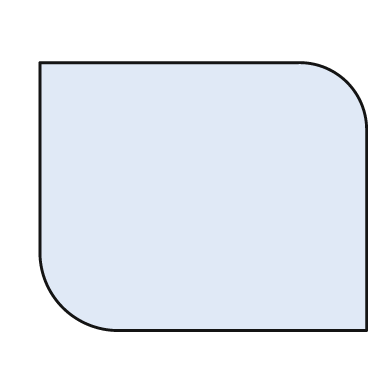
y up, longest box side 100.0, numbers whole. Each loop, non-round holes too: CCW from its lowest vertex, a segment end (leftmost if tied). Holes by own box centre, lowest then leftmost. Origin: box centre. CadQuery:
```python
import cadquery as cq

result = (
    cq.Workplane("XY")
    .moveTo(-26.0, -41.0)
    .lineTo(50.0, -41.0)
    .lineTo(50.0, 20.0)
    .threePointArc((44.0, 35.0), (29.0, 41.0))
    .lineTo(-50.0, 41.0)
    .lineTo(-50.0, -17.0)
    .threePointArc((-43.0, -34.0), (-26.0, -41.0))
    .close()
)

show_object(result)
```